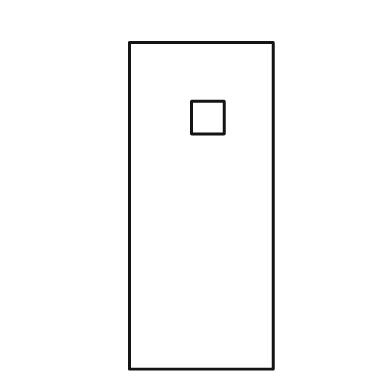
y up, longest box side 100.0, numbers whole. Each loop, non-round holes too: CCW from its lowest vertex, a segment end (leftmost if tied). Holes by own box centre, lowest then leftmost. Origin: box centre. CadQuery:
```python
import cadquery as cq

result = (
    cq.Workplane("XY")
    .moveTo(-22.0, -50.0)
    .lineTo(22.0, -50.0)
    .lineTo(22.0, 50.0)
    .lineTo(-22.0, 50.0)
    .close()
    .moveTo(-3.0, 22.0)
    .lineTo(7.0, 22.0)
    .lineTo(7.0, 32.0)
    .lineTo(-3.0, 32.0)
    .close()
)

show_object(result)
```